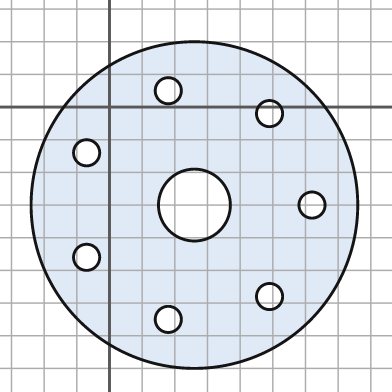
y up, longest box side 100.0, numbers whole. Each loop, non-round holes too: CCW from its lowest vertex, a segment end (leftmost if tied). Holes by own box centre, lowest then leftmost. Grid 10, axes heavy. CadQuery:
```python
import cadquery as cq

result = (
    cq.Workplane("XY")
    .moveTo(26.0, -30.0)
    .circle(50.0)
    .moveTo(18.0, -65.0)
    .circle(4.0)
    .moveTo(49.0, -58.0)
    .circle(4.0)
    .moveTo(-7.0, -46.0)
    .circle(4.0)
    .moveTo(26.0, -30.0)
    .circle(11.0)
    .moveTo(62.0, -30.0)
    .circle(4.0)
    .moveTo(-7.0, -14.0)
    .circle(4.0)
    .moveTo(49.0, -2.0)
    .circle(4.0)
    .moveTo(18.0, 5.0)
    .circle(4.0)
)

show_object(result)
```